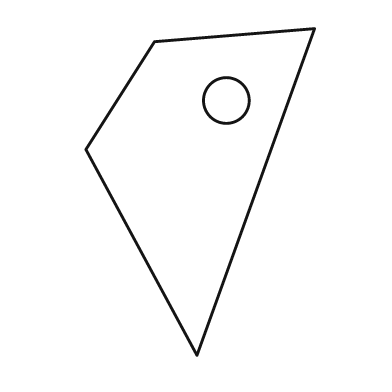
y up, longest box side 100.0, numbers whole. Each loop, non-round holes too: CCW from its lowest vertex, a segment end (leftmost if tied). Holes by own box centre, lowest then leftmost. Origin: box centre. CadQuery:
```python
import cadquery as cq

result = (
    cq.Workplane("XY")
    .moveTo(-1.0, -50.0)
    .lineTo(35.0, 50.0)
    .lineTo(-14.0, 46.0)
    .lineTo(-35.0, 13.0)
    .close()
    .moveTo(8.0, 28.0)
    .circle(7.0)
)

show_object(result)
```